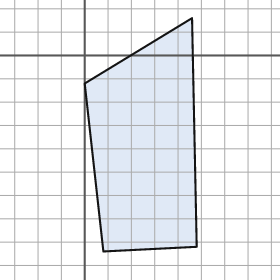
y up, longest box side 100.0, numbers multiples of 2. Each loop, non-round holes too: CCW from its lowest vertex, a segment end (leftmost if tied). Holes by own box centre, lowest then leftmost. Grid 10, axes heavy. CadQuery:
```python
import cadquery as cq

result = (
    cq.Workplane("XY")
    .moveTo(8.0, -84.0)
    .lineTo(48.0, -82.0)
    .lineTo(46.0, 16.0)
    .lineTo(0.0, -12.0)
    .close()
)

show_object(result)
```